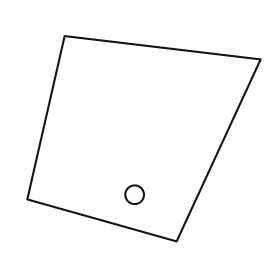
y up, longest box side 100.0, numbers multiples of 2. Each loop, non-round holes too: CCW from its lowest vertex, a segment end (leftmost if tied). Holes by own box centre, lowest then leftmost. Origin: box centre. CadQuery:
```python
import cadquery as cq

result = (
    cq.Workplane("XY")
    .moveTo(14.0, -44.0)
    .lineTo(50.0, 34.0)
    .lineTo(-34.0, 44.0)
    .lineTo(-50.0, -26.0)
    .close()
    .moveTo(-4.0, -24.0)
    .circle(4.0)
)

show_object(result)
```